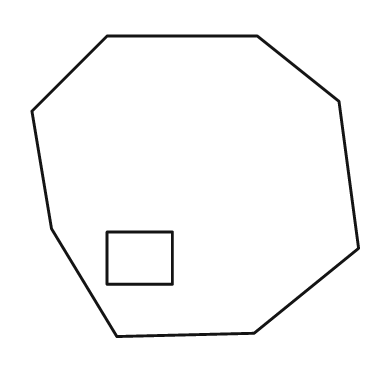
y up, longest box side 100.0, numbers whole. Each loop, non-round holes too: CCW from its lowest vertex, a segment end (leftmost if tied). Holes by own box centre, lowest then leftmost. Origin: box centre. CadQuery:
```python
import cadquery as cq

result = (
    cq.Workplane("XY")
    .moveTo(-24.0, -46.0)
    .lineTo(18.0, -45.0)
    .lineTo(50.0, -19.0)
    .lineTo(44.0, 26.0)
    .lineTo(19.0, 46.0)
    .lineTo(-27.0, 46.0)
    .lineTo(-50.0, 23.0)
    .lineTo(-44.0, -13.0)
    .close()
    .moveTo(-27.0, -30.0)
    .lineTo(-7.0, -30.0)
    .lineTo(-7.0, -14.0)
    .lineTo(-27.0, -14.0)
    .close()
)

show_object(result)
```